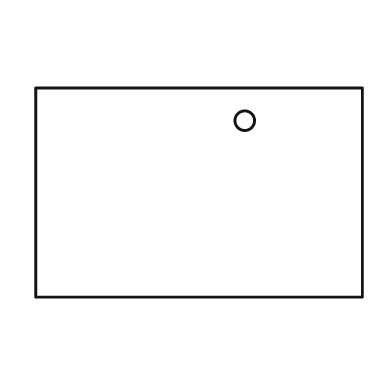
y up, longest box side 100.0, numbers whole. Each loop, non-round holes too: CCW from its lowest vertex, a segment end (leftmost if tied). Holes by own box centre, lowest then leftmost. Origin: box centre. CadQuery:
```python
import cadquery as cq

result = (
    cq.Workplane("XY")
    .moveTo(-50.0, -32.0)
    .lineTo(50.0, -32.0)
    .lineTo(50.0, 32.0)
    .lineTo(-50.0, 32.0)
    .close()
    .moveTo(14.0, 22.0)
    .circle(3.0)
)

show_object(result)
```